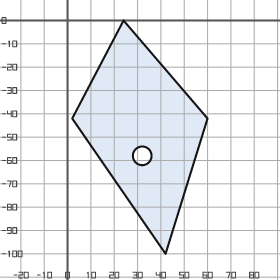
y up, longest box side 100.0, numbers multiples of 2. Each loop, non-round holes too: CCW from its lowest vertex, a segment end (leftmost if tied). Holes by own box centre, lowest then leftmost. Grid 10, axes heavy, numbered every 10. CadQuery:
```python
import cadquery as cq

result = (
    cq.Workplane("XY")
    .moveTo(42.0, -100.0)
    .lineTo(60.0, -42.0)
    .lineTo(24.0, 0.0)
    .lineTo(2.0, -42.0)
    .close()
    .moveTo(32.0, -58.0)
    .circle(4.0)
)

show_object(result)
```